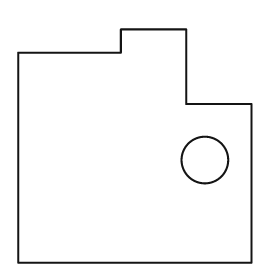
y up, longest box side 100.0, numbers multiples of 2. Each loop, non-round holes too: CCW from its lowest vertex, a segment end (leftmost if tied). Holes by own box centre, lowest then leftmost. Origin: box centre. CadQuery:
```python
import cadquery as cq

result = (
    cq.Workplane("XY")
    .moveTo(-50.0, -50.0)
    .lineTo(50.0, -50.0)
    .lineTo(50.0, 18.0)
    .lineTo(22.0, 18.0)
    .lineTo(22.0, 50.0)
    .lineTo(-6.0, 50.0)
    .lineTo(-6.0, 40.0)
    .lineTo(-50.0, 40.0)
    .close()
    .moveTo(30.0, -6.0)
    .circle(10.0)
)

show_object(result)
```